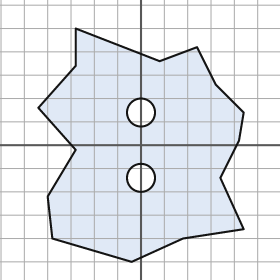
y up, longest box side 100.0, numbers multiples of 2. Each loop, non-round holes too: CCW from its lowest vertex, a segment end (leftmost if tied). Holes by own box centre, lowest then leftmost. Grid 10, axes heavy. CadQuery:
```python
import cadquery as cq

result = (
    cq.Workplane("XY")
    .moveTo(-4.0, -50.0)
    .lineTo(18.0, -40.0)
    .lineTo(44.0, -36.0)
    .lineTo(34.0, -14.0)
    .lineTo(42.0, 2.0)
    .lineTo(44.0, 14.0)
    .lineTo(32.0, 26.0)
    .lineTo(24.0, 42.0)
    .lineTo(8.0, 36.0)
    .lineTo(-28.0, 50.0)
    .lineTo(-28.0, 34.0)
    .lineTo(-44.0, 16.0)
    .lineTo(-28.0, -2.0)
    .lineTo(-40.0, -22.0)
    .lineTo(-38.0, -40.0)
    .close()
    .moveTo(0.0, -14.0)
    .circle(6.0)
    .moveTo(0.0, 14.0)
    .circle(6.0)
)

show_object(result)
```